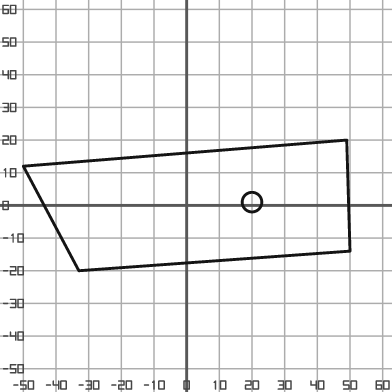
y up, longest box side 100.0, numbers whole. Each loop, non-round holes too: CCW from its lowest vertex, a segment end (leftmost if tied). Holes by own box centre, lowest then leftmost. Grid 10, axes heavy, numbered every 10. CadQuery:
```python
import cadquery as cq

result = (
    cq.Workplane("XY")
    .moveTo(-33.0, -20.0)
    .lineTo(50.0, -14.0)
    .lineTo(49.0, 20.0)
    .lineTo(-50.0, 12.0)
    .close()
    .moveTo(20.0, 1.0)
    .circle(3.0)
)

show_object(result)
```